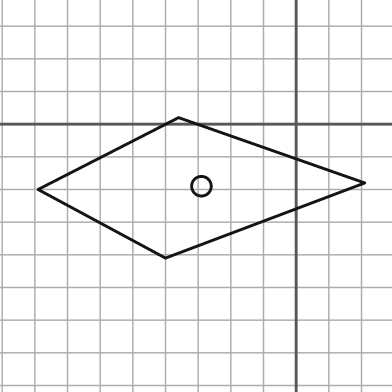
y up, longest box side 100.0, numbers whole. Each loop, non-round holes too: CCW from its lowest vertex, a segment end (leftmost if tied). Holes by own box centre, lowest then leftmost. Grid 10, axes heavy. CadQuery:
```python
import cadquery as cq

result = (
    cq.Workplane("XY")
    .moveTo(-40.0, -41.0)
    .lineTo(21.0, -18.0)
    .lineTo(-36.0, 2.0)
    .lineTo(-79.0, -20.0)
    .close()
    .moveTo(-29.0, -19.0)
    .circle(3.0)
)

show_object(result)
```